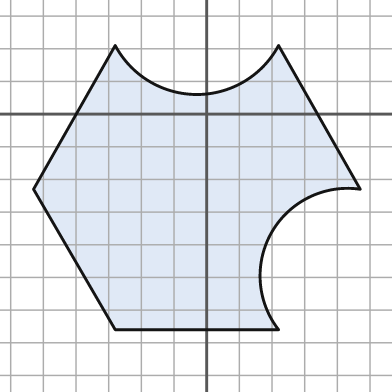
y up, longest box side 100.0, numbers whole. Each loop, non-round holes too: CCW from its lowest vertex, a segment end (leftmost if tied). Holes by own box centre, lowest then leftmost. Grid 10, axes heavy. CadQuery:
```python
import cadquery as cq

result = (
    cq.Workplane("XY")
    .moveTo(-28.0, -66.0)
    .lineTo(22.0, -66.0)
    .threePointArc((20.0, -36.0), (47.0, -23.0))
    .lineTo(22.0, 21.0)
    .threePointArc((-3.0, 6.0), (-28.0, 21.0))
    .lineTo(-53.0, -23.0)
    .close()
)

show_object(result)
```